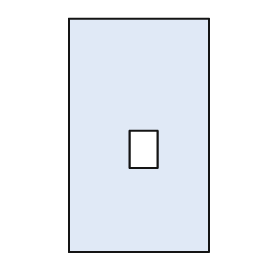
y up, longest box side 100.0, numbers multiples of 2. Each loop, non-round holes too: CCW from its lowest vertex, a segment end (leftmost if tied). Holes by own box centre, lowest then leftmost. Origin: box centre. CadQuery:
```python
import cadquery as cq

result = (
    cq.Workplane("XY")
    .moveTo(-30.0, -50.0)
    .lineTo(30.0, -50.0)
    .lineTo(30.0, 50.0)
    .lineTo(-30.0, 50.0)
    .close()
    .moveTo(-4.0, -14.0)
    .lineTo(8.0, -14.0)
    .lineTo(8.0, 2.0)
    .lineTo(-4.0, 2.0)
    .close()
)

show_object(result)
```